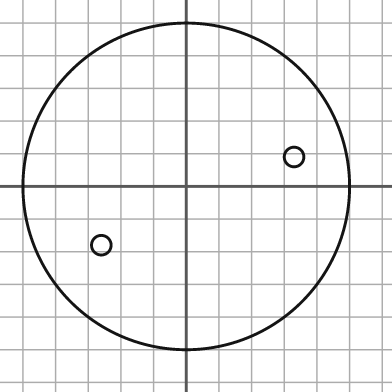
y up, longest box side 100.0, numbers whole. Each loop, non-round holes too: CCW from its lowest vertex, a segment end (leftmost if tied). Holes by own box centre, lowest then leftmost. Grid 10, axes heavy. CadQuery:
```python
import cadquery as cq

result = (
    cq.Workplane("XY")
    .moveTo(0.0, 0.0)
    .circle(50.0)
    .moveTo(-26.0, -18.0)
    .circle(3.0)
    .moveTo(33.0, 9.0)
    .circle(3.0)
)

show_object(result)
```